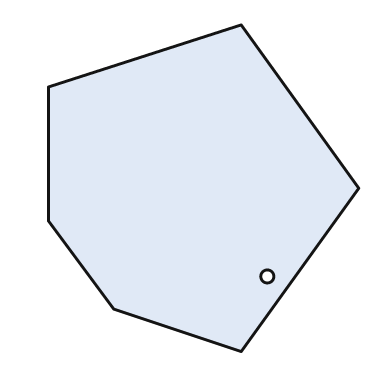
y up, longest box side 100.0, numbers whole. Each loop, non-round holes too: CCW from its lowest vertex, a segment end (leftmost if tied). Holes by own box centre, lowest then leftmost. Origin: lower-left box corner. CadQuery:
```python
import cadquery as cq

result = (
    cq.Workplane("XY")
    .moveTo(59.0, 0.0)
    .lineTo(95.0, 50.0)
    .lineTo(59.0, 100.0)
    .lineTo(0.0, 81.0)
    .lineTo(0.0, 40.0)
    .lineTo(20.0, 13.0)
    .close()
    .moveTo(67.0, 23.0)
    .circle(2.0)
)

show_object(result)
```